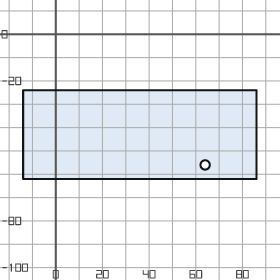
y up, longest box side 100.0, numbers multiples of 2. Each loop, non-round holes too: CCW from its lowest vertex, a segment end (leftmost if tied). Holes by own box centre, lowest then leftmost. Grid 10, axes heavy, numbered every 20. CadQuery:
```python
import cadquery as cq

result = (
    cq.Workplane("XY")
    .moveTo(-14.0, -62.0)
    .lineTo(86.0, -62.0)
    .lineTo(86.0, -24.0)
    .lineTo(-14.0, -24.0)
    .close()
    .moveTo(64.0, -56.0)
    .circle(2.0)
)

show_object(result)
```